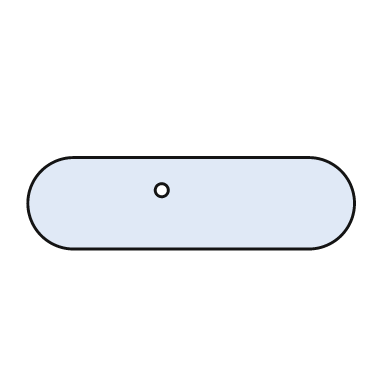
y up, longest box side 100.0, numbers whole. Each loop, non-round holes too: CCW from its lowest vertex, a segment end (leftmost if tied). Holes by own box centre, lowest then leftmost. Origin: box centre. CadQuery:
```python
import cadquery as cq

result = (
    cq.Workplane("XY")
    .moveTo(-36.0, -14.0)
    .lineTo(36.0, -14.0)
    .threePointArc((50.0, 0.0), (36.0, 14.0))
    .lineTo(-36.0, 14.0)
    .threePointArc((-50.0, 0.0), (-36.0, -14.0))
    .close()
    .moveTo(-9.0, 4.0)
    .circle(2.0)
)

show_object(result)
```